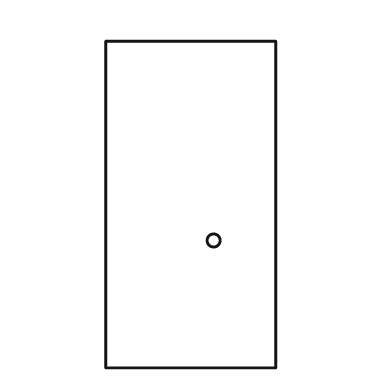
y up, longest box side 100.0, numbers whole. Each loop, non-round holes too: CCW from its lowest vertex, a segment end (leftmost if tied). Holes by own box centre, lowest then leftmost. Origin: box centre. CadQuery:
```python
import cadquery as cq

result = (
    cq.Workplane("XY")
    .moveTo(-26.0, -50.0)
    .lineTo(26.0, -50.0)
    .lineTo(26.0, 50.0)
    .lineTo(-26.0, 50.0)
    .close()
    .moveTo(7.0, -11.0)
    .circle(2.0)
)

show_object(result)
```